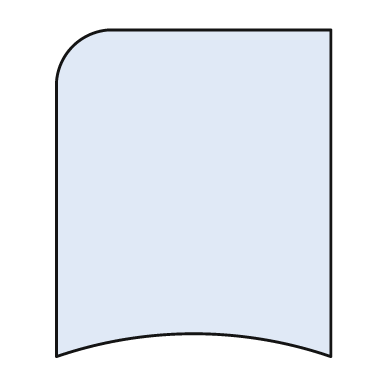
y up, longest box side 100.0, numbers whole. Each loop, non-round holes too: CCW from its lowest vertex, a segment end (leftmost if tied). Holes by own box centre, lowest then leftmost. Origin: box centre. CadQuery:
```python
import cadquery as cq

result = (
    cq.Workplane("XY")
    .moveTo(-42.0, -50.0)
    .threePointArc((0.0, -43.0), (42.0, -50.0))
    .lineTo(42.0, 50.0)
    .lineTo(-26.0, 50.0)
    .threePointArc((-37.0, 45.0), (-42.0, 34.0))
    .close()
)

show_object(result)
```